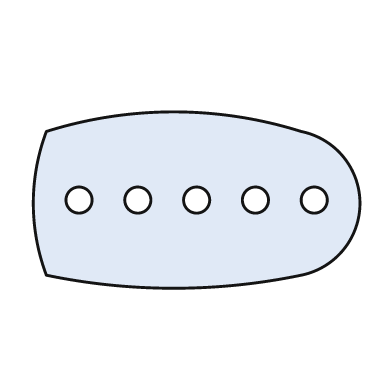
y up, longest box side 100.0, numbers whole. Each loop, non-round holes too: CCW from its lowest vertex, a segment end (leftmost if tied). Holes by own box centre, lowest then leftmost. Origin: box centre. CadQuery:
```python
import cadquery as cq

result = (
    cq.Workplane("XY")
    .moveTo(-46.0, -23.0)
    .threePointArc((-7.0, -27.0), (32.0, -23.0))
    .threePointArc((50.0, -1.0), (32.0, 21.0))
    .threePointArc((-7.0, 27.0), (-46.0, 21.0))
    .threePointArc((-50.0, -1.0), (-46.0, -23.0))
    .close()
    .moveTo(-36.0, 0.0)
    .circle(4.0)
    .moveTo(-18.0, 0.0)
    .circle(4.0)
    .moveTo(0.0, 0.0)
    .circle(4.0)
    .moveTo(18.0, 0.0)
    .circle(4.0)
    .moveTo(36.0, 0.0)
    .circle(4.0)
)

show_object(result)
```